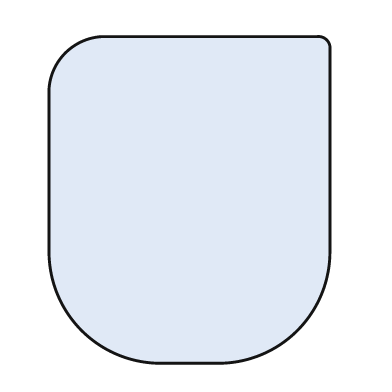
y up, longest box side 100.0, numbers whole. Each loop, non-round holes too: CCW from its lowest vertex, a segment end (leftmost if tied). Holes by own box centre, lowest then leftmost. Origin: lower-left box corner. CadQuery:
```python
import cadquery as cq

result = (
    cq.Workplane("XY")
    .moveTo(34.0, 0.0)
    .lineTo(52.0, 0.0)
    .threePointArc((76.0, 10.0), (86.0, 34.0))
    .lineTo(86.0, 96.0)
    .threePointArc((85.0, 99.0), (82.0, 100.0))
    .lineTo(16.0, 100.0)
    .threePointArc((5.0, 95.0), (0.0, 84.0))
    .lineTo(0.0, 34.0)
    .threePointArc((10.0, 10.0), (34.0, 0.0))
    .close()
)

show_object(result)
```